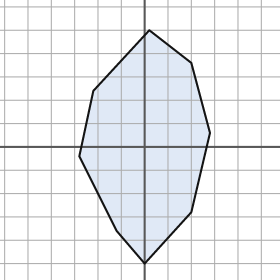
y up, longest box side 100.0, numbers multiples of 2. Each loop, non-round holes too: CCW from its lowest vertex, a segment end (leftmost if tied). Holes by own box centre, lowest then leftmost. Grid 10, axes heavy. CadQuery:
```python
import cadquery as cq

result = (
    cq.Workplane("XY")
    .moveTo(0.0, -50.0)
    .lineTo(20.0, -28.0)
    .lineTo(28.0, 6.0)
    .lineTo(20.0, 36.0)
    .lineTo(2.0, 50.0)
    .lineTo(-22.0, 24.0)
    .lineTo(-28.0, -4.0)
    .lineTo(-12.0, -36.0)
    .close()
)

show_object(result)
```